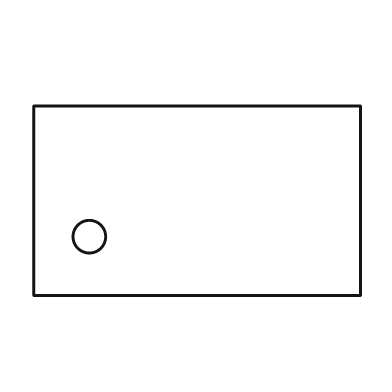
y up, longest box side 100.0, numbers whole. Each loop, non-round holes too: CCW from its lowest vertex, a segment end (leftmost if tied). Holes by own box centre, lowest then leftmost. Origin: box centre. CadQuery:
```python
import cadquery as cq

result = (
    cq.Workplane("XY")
    .moveTo(-50.0, -29.0)
    .lineTo(50.0, -29.0)
    .lineTo(50.0, 29.0)
    .lineTo(-50.0, 29.0)
    .close()
    .moveTo(-33.0, -11.0)
    .circle(5.0)
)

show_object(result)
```